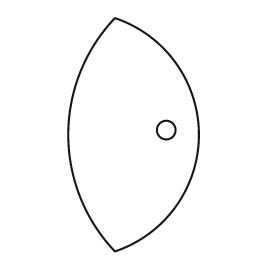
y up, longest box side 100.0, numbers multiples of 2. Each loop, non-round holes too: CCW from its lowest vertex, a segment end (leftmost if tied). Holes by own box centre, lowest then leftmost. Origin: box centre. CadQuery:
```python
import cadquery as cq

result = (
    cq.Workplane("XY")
    .moveTo(-8.0, -50.0)
    .threePointArc((28.0, 0.0), (-8.0, 50.0))
    .threePointArc((-28.0, 0.0), (-8.0, -50.0))
    .close()
    .moveTo(14.0, 2.0)
    .circle(4.0)
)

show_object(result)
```